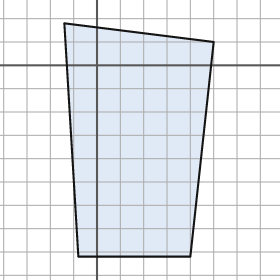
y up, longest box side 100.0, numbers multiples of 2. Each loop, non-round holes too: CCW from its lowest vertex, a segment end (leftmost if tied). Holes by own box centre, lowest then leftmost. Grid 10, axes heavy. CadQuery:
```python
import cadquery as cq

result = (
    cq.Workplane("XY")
    .moveTo(-8.0, -82.0)
    .lineTo(40.0, -82.0)
    .lineTo(50.0, 10.0)
    .lineTo(-14.0, 18.0)
    .close()
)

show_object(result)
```